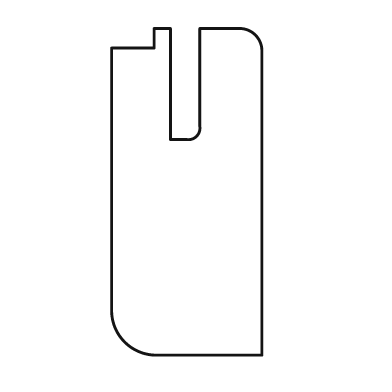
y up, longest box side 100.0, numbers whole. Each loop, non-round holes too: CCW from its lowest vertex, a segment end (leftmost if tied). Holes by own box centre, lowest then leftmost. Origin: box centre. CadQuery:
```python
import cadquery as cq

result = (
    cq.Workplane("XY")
    .moveTo(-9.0, -50.0)
    .lineTo(23.0, -50.0)
    .lineTo(23.0, 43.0)
    .threePointArc((21.0, 48.0), (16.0, 50.0))
    .lineTo(4.0, 50.0)
    .lineTo(4.0, 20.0)
    .threePointArc((3.0, 17.0), (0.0, 16.0))
    .lineTo(-5.0, 16.0)
    .lineTo(-5.0, 50.0)
    .lineTo(-10.0, 50.0)
    .lineTo(-10.0, 44.0)
    .lineTo(-23.0, 44.0)
    .lineTo(-23.0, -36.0)
    .threePointArc((-19.0, -46.0), (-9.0, -50.0))
    .close()
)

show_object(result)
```